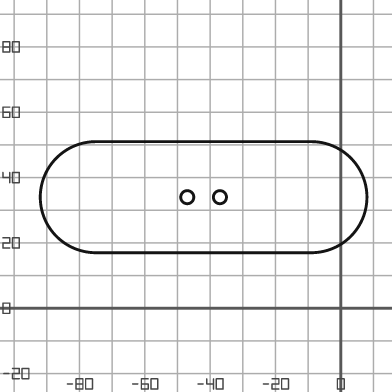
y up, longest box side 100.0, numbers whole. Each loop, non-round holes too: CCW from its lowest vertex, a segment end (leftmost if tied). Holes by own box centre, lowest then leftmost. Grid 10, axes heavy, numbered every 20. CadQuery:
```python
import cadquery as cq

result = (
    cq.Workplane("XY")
    .moveTo(-75.0, 17.0)
    .lineTo(-9.0, 17.0)
    .threePointArc((8.0, 34.0), (-9.0, 51.0))
    .lineTo(-75.0, 51.0)
    .threePointArc((-92.0, 34.0), (-75.0, 17.0))
    .close()
    .moveTo(-47.0, 34.0)
    .circle(2.0)
    .moveTo(-37.0, 34.0)
    .circle(2.0)
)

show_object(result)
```